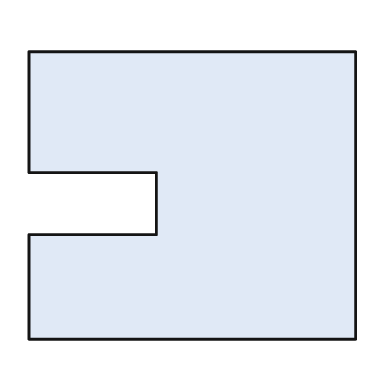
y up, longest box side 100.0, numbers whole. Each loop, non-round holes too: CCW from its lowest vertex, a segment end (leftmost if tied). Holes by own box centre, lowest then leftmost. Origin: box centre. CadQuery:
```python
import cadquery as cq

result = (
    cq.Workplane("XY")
    .moveTo(-50.0, -44.0)
    .lineTo(50.0, -44.0)
    .lineTo(50.0, 44.0)
    .lineTo(-50.0, 44.0)
    .lineTo(-50.0, 7.0)
    .lineTo(-11.0, 7.0)
    .lineTo(-11.0, -12.0)
    .lineTo(-50.0, -12.0)
    .close()
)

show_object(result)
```